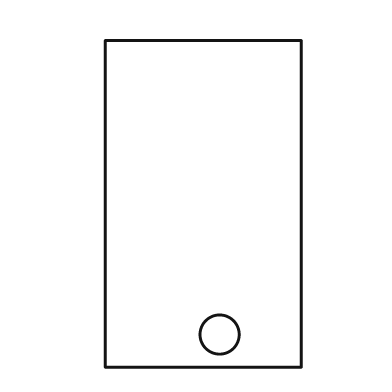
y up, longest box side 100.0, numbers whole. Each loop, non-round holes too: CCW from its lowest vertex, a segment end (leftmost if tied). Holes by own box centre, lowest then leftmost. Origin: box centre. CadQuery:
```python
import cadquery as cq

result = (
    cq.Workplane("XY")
    .moveTo(-30.0, -50.0)
    .lineTo(30.0, -50.0)
    .lineTo(30.0, 50.0)
    .lineTo(-30.0, 50.0)
    .close()
    .moveTo(5.0, -40.0)
    .circle(6.0)
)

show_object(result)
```